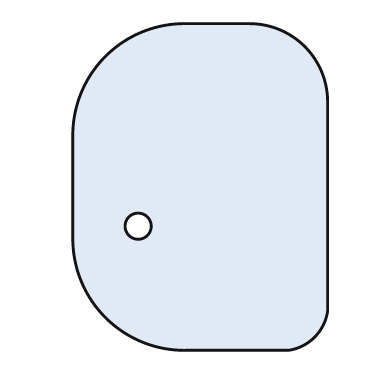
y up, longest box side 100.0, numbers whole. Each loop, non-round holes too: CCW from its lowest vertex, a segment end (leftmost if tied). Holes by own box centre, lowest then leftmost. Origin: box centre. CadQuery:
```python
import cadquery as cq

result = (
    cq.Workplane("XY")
    .moveTo(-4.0, -50.0)
    .lineTo(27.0, -50.0)
    .threePointArc((35.0, -46.0), (39.0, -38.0))
    .lineTo(39.0, 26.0)
    .threePointArc((32.0, 43.0), (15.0, 50.0))
    .lineTo(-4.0, 50.0)
    .threePointArc((-29.0, 40.0), (-39.0, 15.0))
    .lineTo(-39.0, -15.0)
    .threePointArc((-29.0, -40.0), (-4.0, -50.0))
    .close()
    .moveTo(-19.0, -12.0)
    .circle(4.0)
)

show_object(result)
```